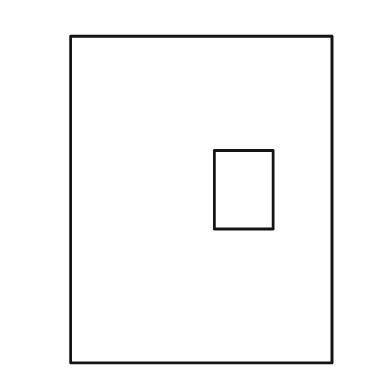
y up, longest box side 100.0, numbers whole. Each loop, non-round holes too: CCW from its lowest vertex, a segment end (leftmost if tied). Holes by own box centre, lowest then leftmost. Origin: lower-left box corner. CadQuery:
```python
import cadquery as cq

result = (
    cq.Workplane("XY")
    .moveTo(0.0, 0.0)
    .lineTo(80.0, 0.0)
    .lineTo(80.0, 100.0)
    .lineTo(0.0, 100.0)
    .close()
    .moveTo(44.0, 41.0)
    .lineTo(62.0, 41.0)
    .lineTo(62.0, 65.0)
    .lineTo(44.0, 65.0)
    .close()
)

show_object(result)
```